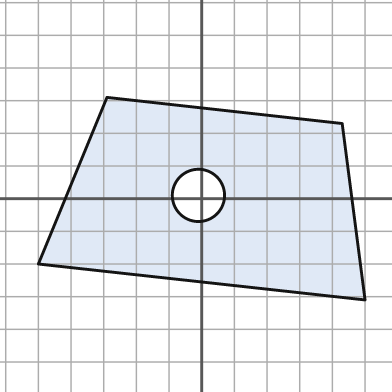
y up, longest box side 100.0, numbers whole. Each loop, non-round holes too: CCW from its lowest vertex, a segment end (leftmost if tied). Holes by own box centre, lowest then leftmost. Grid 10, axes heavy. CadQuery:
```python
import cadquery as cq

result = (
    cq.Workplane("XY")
    .moveTo(50.0, -31.0)
    .lineTo(43.0, 23.0)
    .lineTo(-29.0, 31.0)
    .lineTo(-50.0, -20.0)
    .close()
    .moveTo(-1.0, 1.0)
    .circle(8.0)
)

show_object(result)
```